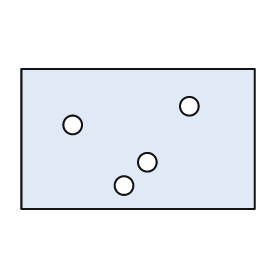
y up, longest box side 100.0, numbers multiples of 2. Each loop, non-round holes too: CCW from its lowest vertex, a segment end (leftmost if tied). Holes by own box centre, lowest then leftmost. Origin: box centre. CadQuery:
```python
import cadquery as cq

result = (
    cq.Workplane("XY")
    .moveTo(-50.0, -30.0)
    .lineTo(50.0, -30.0)
    .lineTo(50.0, 30.0)
    .lineTo(-50.0, 30.0)
    .close()
    .moveTo(-6.0, -20.0)
    .circle(4.0)
    .moveTo(4.0, -10.0)
    .circle(4.0)
    .moveTo(-28.0, 6.0)
    .circle(4.0)
    .moveTo(22.0, 14.0)
    .circle(4.0)
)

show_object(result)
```